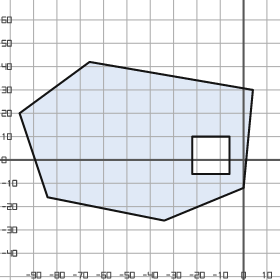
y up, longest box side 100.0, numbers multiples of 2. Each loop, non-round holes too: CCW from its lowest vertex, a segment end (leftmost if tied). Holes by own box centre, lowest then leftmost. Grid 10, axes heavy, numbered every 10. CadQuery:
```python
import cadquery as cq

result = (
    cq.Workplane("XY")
    .moveTo(-34.0, -26.0)
    .lineTo(0.0, -12.0)
    .lineTo(4.0, 30.0)
    .lineTo(-66.0, 42.0)
    .lineTo(-96.0, 20.0)
    .lineTo(-84.0, -16.0)
    .close()
    .moveTo(-22.0, -6.0)
    .lineTo(-6.0, -6.0)
    .lineTo(-6.0, 10.0)
    .lineTo(-22.0, 10.0)
    .close()
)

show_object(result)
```